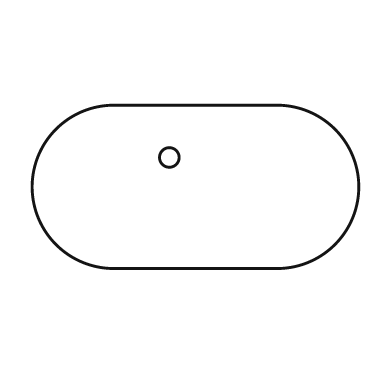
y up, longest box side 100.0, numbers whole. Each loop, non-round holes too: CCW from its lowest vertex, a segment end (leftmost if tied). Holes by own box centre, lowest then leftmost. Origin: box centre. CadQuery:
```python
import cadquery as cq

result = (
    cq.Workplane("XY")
    .moveTo(-25.0, -25.0)
    .lineTo(25.0, -25.0)
    .threePointArc((50.0, 0.0), (25.0, 25.0))
    .lineTo(-25.0, 25.0)
    .threePointArc((-50.0, 0.0), (-25.0, -25.0))
    .close()
    .moveTo(-8.0, 9.0)
    .circle(3.0)
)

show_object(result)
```